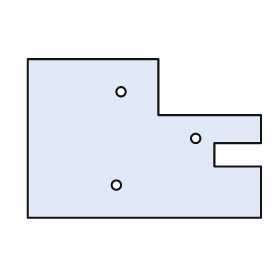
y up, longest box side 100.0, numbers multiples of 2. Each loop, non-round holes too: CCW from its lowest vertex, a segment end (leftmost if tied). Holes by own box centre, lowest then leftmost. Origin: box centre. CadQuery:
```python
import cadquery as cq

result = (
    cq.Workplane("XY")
    .moveTo(-50.0, -34.0)
    .lineTo(50.0, -34.0)
    .lineTo(50.0, -12.0)
    .lineTo(30.0, -12.0)
    .lineTo(30.0, -2.0)
    .lineTo(50.0, -2.0)
    .lineTo(50.0, 10.0)
    .lineTo(6.0, 10.0)
    .lineTo(6.0, 34.0)
    .lineTo(-50.0, 34.0)
    .close()
    .moveTo(-12.0, -20.0)
    .circle(2.0)
    .moveTo(22.0, 0.0)
    .circle(2.0)
    .moveTo(-10.0, 20.0)
    .circle(2.0)
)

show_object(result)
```